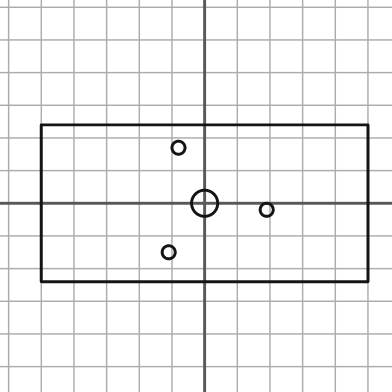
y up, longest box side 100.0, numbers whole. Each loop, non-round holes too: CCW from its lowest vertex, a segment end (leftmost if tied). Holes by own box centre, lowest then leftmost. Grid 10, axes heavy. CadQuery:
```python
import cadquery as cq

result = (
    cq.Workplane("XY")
    .moveTo(-50.0, -24.0)
    .lineTo(50.0, -24.0)
    .lineTo(50.0, 24.0)
    .lineTo(-50.0, 24.0)
    .close()
    .moveTo(-11.0, -15.0)
    .circle(2.0)
    .moveTo(19.0, -2.0)
    .circle(2.0)
    .moveTo(0.0, 0.0)
    .circle(4.0)
    .moveTo(-8.0, 17.0)
    .circle(2.0)
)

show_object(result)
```